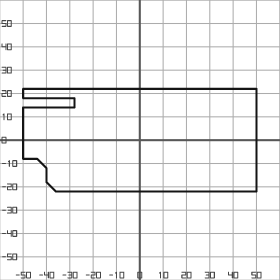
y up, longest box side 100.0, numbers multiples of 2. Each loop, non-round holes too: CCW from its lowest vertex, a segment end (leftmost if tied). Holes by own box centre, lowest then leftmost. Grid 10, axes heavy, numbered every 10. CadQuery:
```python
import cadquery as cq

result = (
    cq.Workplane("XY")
    .moveTo(-36.0, -22.0)
    .lineTo(50.0, -22.0)
    .lineTo(50.0, 22.0)
    .lineTo(-50.0, 22.0)
    .lineTo(-50.0, 18.0)
    .lineTo(-28.0, 18.0)
    .lineTo(-28.0, 14.0)
    .lineTo(-50.0, 14.0)
    .lineTo(-50.0, -8.0)
    .lineTo(-44.0, -8.0)
    .lineTo(-40.0, -12.0)
    .lineTo(-40.0, -18.0)
    .close()
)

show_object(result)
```